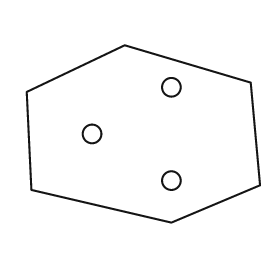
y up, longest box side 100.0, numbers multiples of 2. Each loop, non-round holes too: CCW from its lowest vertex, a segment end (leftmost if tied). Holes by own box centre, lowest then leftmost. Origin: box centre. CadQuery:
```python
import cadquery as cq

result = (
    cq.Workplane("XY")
    .moveTo(12.0, -38.0)
    .lineTo(50.0, -22.0)
    .lineTo(46.0, 22.0)
    .lineTo(-8.0, 38.0)
    .lineTo(-50.0, 18.0)
    .lineTo(-48.0, -24.0)
    .close()
    .moveTo(12.0, -20.0)
    .circle(4.0)
    .moveTo(-22.0, 0.0)
    .circle(4.0)
    .moveTo(12.0, 20.0)
    .circle(4.0)
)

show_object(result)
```